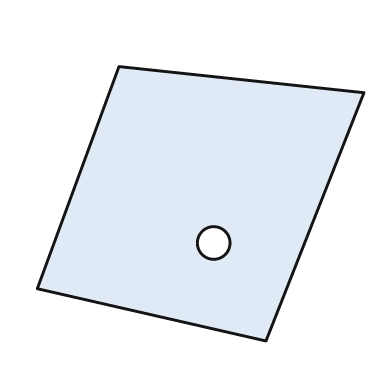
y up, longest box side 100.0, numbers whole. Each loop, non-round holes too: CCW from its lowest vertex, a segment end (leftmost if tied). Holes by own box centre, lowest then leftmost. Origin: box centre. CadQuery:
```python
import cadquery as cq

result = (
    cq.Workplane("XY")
    .moveTo(20.0, -42.0)
    .lineTo(50.0, 34.0)
    .lineTo(-25.0, 42.0)
    .lineTo(-50.0, -26.0)
    .close()
    .moveTo(4.0, -12.0)
    .circle(5.0)
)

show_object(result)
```